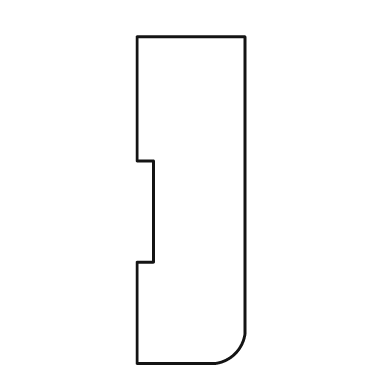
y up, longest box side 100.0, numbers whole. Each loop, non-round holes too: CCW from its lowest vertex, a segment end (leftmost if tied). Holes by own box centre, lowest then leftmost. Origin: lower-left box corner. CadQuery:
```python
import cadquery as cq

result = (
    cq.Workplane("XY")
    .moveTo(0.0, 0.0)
    .lineTo(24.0, 0.0)
    .threePointArc((30.0, 3.0), (33.0, 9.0))
    .lineTo(33.0, 100.0)
    .lineTo(0.0, 100.0)
    .lineTo(0.0, 62.0)
    .lineTo(5.0, 62.0)
    .lineTo(5.0, 31.0)
    .lineTo(0.0, 31.0)
    .close()
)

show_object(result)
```